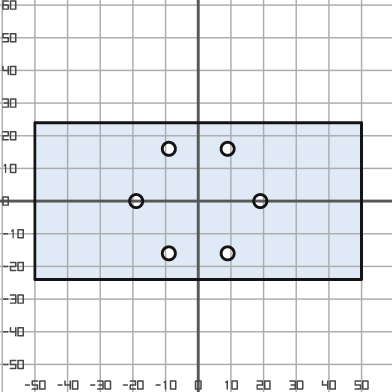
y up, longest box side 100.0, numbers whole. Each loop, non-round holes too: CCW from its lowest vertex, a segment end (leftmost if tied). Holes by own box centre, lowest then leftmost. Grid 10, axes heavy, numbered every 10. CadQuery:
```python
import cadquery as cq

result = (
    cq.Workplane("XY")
    .moveTo(-50.0, -24.0)
    .lineTo(50.0, -24.0)
    .lineTo(50.0, 24.0)
    .lineTo(-50.0, 24.0)
    .close()
    .moveTo(-9.0, -16.0)
    .circle(2.0)
    .moveTo(9.0, -16.0)
    .circle(2.0)
    .moveTo(-19.0, 0.0)
    .circle(2.0)
    .moveTo(19.0, 0.0)
    .circle(2.0)
    .moveTo(-9.0, 16.0)
    .circle(2.0)
    .moveTo(9.0, 16.0)
    .circle(2.0)
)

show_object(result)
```